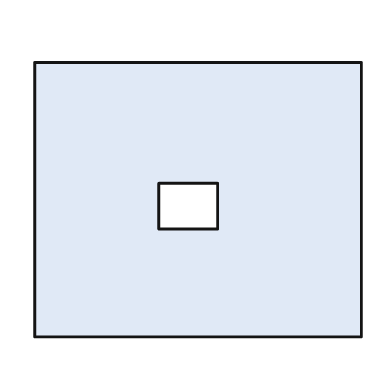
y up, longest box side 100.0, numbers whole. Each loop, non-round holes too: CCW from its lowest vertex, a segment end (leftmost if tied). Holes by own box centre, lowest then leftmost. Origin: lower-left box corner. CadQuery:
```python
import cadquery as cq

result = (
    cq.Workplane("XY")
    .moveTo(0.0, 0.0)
    .lineTo(100.0, 0.0)
    .lineTo(100.0, 84.0)
    .lineTo(0.0, 84.0)
    .close()
    .moveTo(38.0, 33.0)
    .lineTo(56.0, 33.0)
    .lineTo(56.0, 47.0)
    .lineTo(38.0, 47.0)
    .close()
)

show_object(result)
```